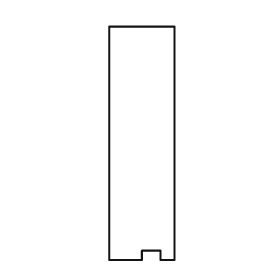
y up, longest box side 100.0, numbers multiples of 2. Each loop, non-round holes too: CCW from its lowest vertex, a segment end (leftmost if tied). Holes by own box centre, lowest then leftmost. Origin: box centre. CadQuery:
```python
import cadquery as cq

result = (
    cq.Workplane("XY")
    .moveTo(-14.0, -50.0)
    .lineTo(0.0, -50.0)
    .lineTo(0.0, -46.0)
    .lineTo(8.0, -46.0)
    .lineTo(8.0, -50.0)
    .lineTo(14.0, -50.0)
    .lineTo(14.0, 50.0)
    .lineTo(-14.0, 50.0)
    .close()
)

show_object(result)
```